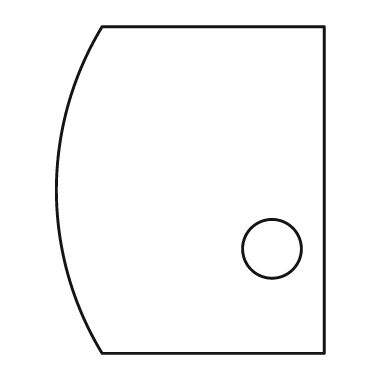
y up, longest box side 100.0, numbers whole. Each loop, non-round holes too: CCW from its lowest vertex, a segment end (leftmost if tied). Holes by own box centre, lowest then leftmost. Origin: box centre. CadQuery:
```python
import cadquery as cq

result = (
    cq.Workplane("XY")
    .moveTo(-27.0, -50.0)
    .lineTo(41.0, -50.0)
    .lineTo(41.0, 50.0)
    .lineTo(-27.0, 50.0)
    .threePointArc((-41.0, 0.0), (-27.0, -50.0))
    .close()
    .moveTo(25.0, -18.0)
    .circle(9.0)
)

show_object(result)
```